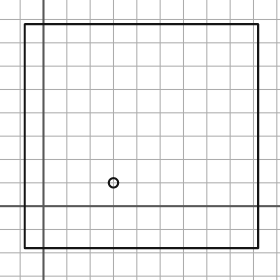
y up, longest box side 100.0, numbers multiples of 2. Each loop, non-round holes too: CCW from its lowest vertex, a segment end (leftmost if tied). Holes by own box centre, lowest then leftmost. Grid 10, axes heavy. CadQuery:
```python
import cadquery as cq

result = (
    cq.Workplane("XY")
    .moveTo(-8.0, -18.0)
    .lineTo(92.0, -18.0)
    .lineTo(92.0, 78.0)
    .lineTo(-8.0, 78.0)
    .close()
    .moveTo(30.0, 10.0)
    .circle(2.0)
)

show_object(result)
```